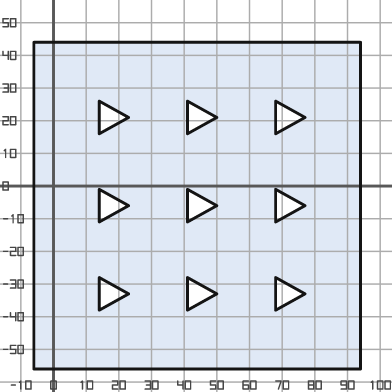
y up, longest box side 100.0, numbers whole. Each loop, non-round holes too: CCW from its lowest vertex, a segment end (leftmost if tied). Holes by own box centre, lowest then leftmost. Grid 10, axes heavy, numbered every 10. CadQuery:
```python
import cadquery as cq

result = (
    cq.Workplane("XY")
    .moveTo(-6.0, -56.0)
    .lineTo(94.0, -56.0)
    .lineTo(94.0, 44.0)
    .lineTo(-6.0, 44.0)
    .close()
    .moveTo(14.0, -38.0)
    .lineTo(23.0, -33.0)
    .lineTo(14.0, -28.0)
    .close()
    .moveTo(41.0, -38.0)
    .lineTo(50.0, -33.0)
    .lineTo(41.0, -28.0)
    .close()
    .moveTo(68.0, -38.0)
    .lineTo(77.0, -33.0)
    .lineTo(68.0, -28.0)
    .close()
    .moveTo(14.0, -11.0)
    .lineTo(23.0, -6.0)
    .lineTo(14.0, -1.0)
    .close()
    .moveTo(41.0, -11.0)
    .lineTo(50.0, -6.0)
    .lineTo(41.0, -1.0)
    .close()
    .moveTo(68.0, -11.0)
    .lineTo(77.0, -6.0)
    .lineTo(68.0, -1.0)
    .close()
    .moveTo(14.0, 16.0)
    .lineTo(23.0, 21.0)
    .lineTo(14.0, 26.0)
    .close()
    .moveTo(41.0, 16.0)
    .lineTo(50.0, 21.0)
    .lineTo(41.0, 26.0)
    .close()
    .moveTo(68.0, 16.0)
    .lineTo(77.0, 21.0)
    .lineTo(68.0, 26.0)
    .close()
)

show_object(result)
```